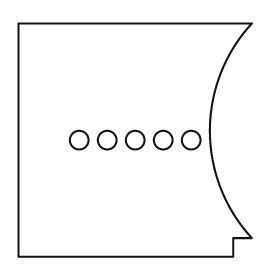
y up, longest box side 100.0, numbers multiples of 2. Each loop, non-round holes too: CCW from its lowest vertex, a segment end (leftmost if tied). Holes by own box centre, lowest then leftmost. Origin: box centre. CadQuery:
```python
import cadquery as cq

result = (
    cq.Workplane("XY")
    .moveTo(-50.0, -50.0)
    .lineTo(42.0, -50.0)
    .lineTo(42.0, -42.0)
    .lineTo(50.0, -42.0)
    .threePointArc((32.0, 4.0), (50.0, 50.0))
    .lineTo(-50.0, 50.0)
    .close()
    .moveTo(-24.0, 0.0)
    .circle(4.0)
    .moveTo(-12.0, 0.0)
    .circle(4.0)
    .moveTo(0.0, 0.0)
    .circle(4.0)
    .moveTo(12.0, 0.0)
    .circle(4.0)
    .moveTo(24.0, 0.0)
    .circle(4.0)
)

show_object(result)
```